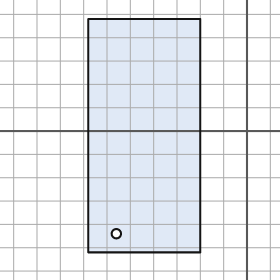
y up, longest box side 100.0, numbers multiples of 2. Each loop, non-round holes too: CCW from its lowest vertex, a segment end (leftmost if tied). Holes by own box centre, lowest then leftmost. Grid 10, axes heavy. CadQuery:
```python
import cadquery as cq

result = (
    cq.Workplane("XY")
    .moveTo(-68.0, -52.0)
    .lineTo(-20.0, -52.0)
    .lineTo(-20.0, 48.0)
    .lineTo(-68.0, 48.0)
    .close()
    .moveTo(-56.0, -44.0)
    .circle(2.0)
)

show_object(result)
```